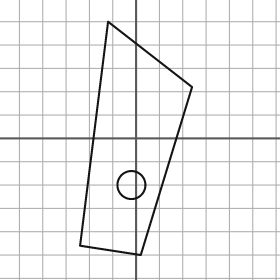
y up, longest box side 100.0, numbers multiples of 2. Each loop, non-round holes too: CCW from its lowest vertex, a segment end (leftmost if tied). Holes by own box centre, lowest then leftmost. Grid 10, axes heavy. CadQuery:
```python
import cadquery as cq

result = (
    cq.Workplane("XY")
    .moveTo(2.0, -50.0)
    .lineTo(24.0, 22.0)
    .lineTo(-12.0, 50.0)
    .lineTo(-24.0, -46.0)
    .close()
    .moveTo(-2.0, -20.0)
    .circle(6.0)
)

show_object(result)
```